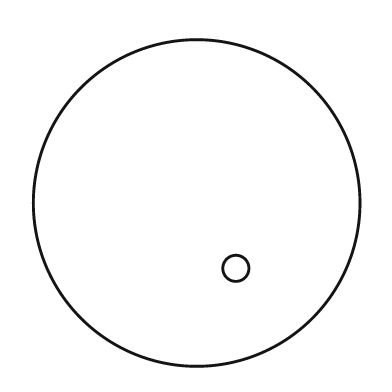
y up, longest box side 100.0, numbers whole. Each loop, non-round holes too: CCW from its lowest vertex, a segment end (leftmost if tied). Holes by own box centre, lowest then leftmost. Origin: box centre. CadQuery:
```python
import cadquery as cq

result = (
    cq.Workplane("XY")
    .moveTo(0.0, 0.0)
    .circle(50.0)
    .moveTo(12.0, -20.0)
    .circle(4.0)
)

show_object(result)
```